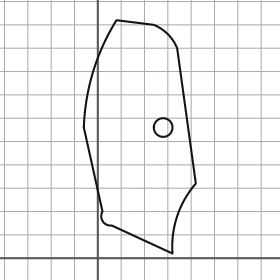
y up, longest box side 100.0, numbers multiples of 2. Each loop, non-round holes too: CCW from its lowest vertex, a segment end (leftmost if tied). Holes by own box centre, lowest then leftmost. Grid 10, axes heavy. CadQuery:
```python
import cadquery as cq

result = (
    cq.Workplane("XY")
    .moveTo(32.0, 2.0)
    .threePointArc((34.0, 18.0), (42.0, 32.0))
    .lineTo(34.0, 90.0)
    .threePointArc((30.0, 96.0), (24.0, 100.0))
    .lineTo(8.0, 102.0)
    .threePointArc((-2.0, 80.0), (-6.0, 56.0))
    .lineTo(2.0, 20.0)
    .threePointArc((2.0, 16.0), (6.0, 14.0))
    .close()
    .moveTo(28.0, 56.0)
    .circle(4.0)
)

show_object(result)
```